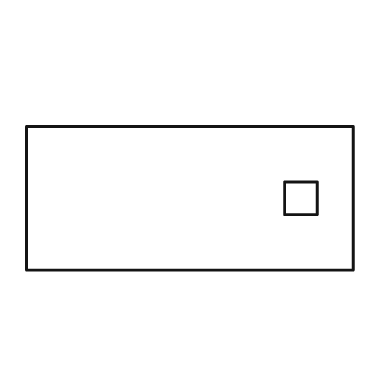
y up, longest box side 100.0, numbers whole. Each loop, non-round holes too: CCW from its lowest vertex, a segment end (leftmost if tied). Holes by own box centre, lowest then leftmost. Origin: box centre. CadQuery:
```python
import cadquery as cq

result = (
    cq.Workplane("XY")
    .moveTo(-50.0, -22.0)
    .lineTo(50.0, -22.0)
    .lineTo(50.0, 22.0)
    .lineTo(-50.0, 22.0)
    .close()
    .moveTo(29.0, -5.0)
    .lineTo(39.0, -5.0)
    .lineTo(39.0, 5.0)
    .lineTo(29.0, 5.0)
    .close()
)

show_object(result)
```